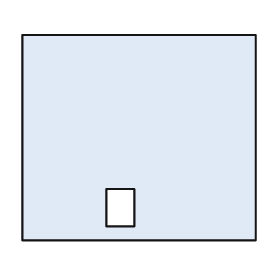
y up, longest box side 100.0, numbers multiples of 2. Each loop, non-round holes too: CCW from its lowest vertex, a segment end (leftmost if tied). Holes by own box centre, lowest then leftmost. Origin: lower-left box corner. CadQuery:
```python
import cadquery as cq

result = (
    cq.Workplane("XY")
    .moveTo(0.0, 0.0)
    .lineTo(100.0, 0.0)
    .lineTo(100.0, 88.0)
    .lineTo(0.0, 88.0)
    .close()
    .moveTo(36.0, 6.0)
    .lineTo(48.0, 6.0)
    .lineTo(48.0, 22.0)
    .lineTo(36.0, 22.0)
    .close()
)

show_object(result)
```